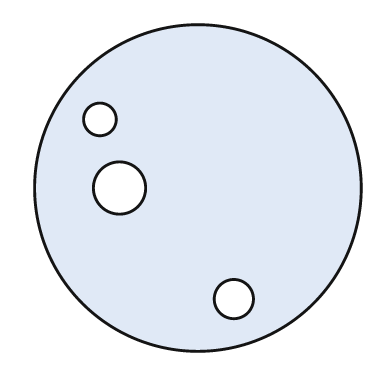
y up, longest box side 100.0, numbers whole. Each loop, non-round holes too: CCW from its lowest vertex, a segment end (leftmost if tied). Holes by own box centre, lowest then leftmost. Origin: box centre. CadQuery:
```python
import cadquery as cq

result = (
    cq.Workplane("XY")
    .moveTo(0.0, 0.0)
    .circle(50.0)
    .moveTo(11.0, -34.0)
    .circle(6.0)
    .moveTo(-24.0, 0.0)
    .circle(8.0)
    .moveTo(-30.0, 21.0)
    .circle(5.0)
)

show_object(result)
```